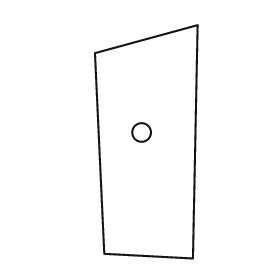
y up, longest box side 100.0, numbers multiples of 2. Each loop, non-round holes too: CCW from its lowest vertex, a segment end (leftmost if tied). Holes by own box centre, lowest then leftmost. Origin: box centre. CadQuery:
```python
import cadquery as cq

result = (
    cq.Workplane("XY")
    .moveTo(20.0, -50.0)
    .lineTo(22.0, 50.0)
    .lineTo(-22.0, 38.0)
    .lineTo(-18.0, -48.0)
    .close()
    .moveTo(-2.0, 4.0)
    .circle(4.0)
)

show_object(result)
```